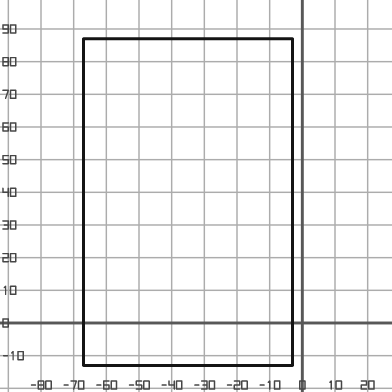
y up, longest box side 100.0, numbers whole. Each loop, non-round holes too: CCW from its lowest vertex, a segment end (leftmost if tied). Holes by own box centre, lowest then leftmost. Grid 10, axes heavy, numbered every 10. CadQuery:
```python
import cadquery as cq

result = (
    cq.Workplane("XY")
    .moveTo(-67.0, -13.0)
    .lineTo(-3.0, -13.0)
    .lineTo(-3.0, 87.0)
    .lineTo(-67.0, 87.0)
    .close()
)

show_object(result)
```